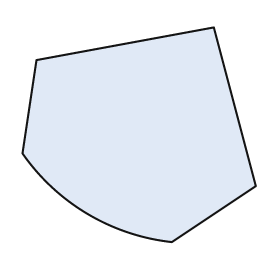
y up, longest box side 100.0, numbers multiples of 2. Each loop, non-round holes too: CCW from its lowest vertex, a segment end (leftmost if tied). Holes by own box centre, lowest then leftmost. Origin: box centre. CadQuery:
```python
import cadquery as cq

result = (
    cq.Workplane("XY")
    .moveTo(14.0, -46.0)
    .lineTo(50.0, -22.0)
    .lineTo(32.0, 46.0)
    .lineTo(-44.0, 32.0)
    .lineTo(-50.0, -8.0)
    .threePointArc((-22.0, -34.0), (14.0, -46.0))
    .close()
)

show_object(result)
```